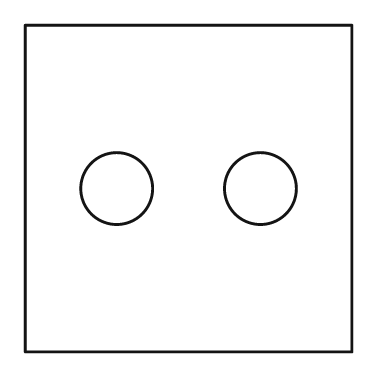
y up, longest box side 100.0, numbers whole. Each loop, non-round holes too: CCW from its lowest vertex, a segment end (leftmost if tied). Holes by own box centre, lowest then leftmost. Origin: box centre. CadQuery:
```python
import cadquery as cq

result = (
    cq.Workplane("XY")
    .moveTo(-50.0, -50.0)
    .lineTo(50.0, -50.0)
    .lineTo(50.0, 50.0)
    .lineTo(-50.0, 50.0)
    .close()
    .moveTo(-22.0, 0.0)
    .circle(11.0)
    .moveTo(22.0, 0.0)
    .circle(11.0)
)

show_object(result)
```